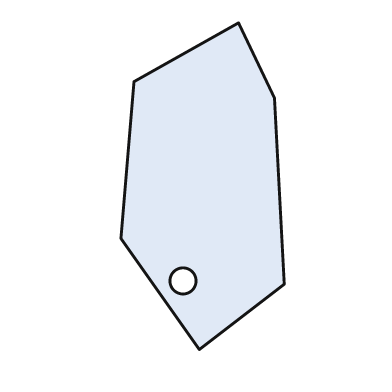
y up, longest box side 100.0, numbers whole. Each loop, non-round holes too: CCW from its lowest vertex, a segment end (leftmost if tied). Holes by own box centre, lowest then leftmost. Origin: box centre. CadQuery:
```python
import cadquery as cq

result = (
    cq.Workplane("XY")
    .moveTo(-1.0, -50.0)
    .lineTo(25.0, -30.0)
    .lineTo(22.0, 27.0)
    .lineTo(11.0, 50.0)
    .lineTo(-21.0, 32.0)
    .lineTo(-25.0, -16.0)
    .close()
    .moveTo(-6.0, -29.0)
    .circle(4.0)
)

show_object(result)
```